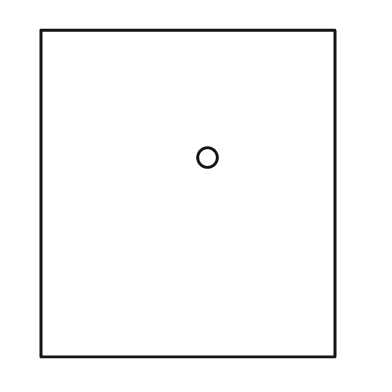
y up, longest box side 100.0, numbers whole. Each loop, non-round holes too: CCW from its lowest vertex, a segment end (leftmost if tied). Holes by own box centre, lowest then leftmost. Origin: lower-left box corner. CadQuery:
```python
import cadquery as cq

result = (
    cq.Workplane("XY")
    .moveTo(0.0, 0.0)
    .lineTo(90.0, 0.0)
    .lineTo(90.0, 100.0)
    .lineTo(0.0, 100.0)
    .close()
    .moveTo(51.0, 61.0)
    .circle(3.0)
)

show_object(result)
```